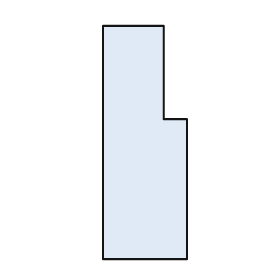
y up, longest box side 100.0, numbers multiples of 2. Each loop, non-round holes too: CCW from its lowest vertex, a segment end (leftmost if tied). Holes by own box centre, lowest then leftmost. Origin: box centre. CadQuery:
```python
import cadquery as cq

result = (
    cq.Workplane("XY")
    .moveTo(-18.0, -50.0)
    .lineTo(18.0, -50.0)
    .lineTo(18.0, 10.0)
    .lineTo(8.0, 10.0)
    .lineTo(8.0, 50.0)
    .lineTo(-18.0, 50.0)
    .close()
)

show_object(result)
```